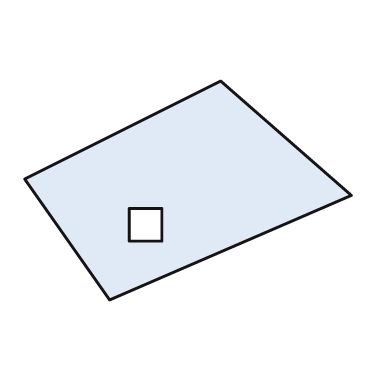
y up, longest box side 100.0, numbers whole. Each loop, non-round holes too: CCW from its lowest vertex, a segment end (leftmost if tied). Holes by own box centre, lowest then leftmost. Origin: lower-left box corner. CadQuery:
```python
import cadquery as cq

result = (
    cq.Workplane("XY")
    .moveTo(26.0, 0.0)
    .lineTo(100.0, 32.0)
    .lineTo(60.0, 67.0)
    .lineTo(0.0, 37.0)
    .close()
    .moveTo(32.0, 18.0)
    .lineTo(42.0, 18.0)
    .lineTo(42.0, 28.0)
    .lineTo(32.0, 28.0)
    .close()
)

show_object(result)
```